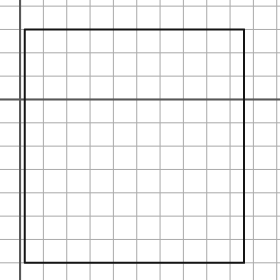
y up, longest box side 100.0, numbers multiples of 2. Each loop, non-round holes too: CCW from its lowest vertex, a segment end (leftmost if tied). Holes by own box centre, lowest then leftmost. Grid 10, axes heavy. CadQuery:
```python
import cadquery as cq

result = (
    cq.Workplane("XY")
    .moveTo(2.0, -70.0)
    .lineTo(96.0, -70.0)
    .lineTo(96.0, 30.0)
    .lineTo(2.0, 30.0)
    .close()
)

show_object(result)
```